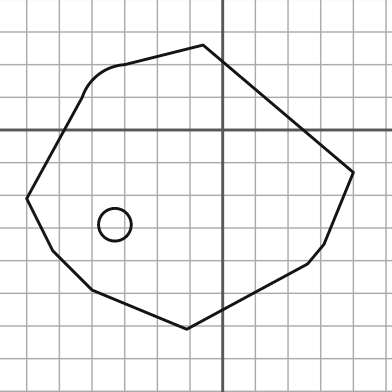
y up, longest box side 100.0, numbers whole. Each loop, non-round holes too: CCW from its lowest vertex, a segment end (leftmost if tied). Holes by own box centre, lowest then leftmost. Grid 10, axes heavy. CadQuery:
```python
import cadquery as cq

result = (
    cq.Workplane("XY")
    .moveTo(-11.0, -61.0)
    .lineTo(26.0, -41.0)
    .lineTo(31.0, -35.0)
    .lineTo(40.0, -13.0)
    .lineTo(-6.0, 26.0)
    .lineTo(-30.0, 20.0)
    .threePointArc((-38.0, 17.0), (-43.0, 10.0))
    .lineTo(-60.0, -21.0)
    .lineTo(-52.0, -37.0)
    .lineTo(-40.0, -49.0)
    .close()
    .moveTo(-33.0, -29.0)
    .circle(5.0)
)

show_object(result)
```